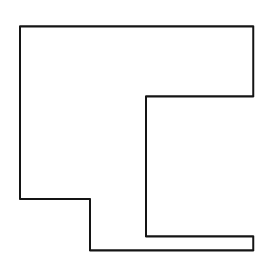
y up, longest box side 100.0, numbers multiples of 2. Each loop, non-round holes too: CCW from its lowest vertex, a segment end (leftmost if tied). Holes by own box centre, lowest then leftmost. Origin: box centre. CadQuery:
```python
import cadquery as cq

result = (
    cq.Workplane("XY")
    .moveTo(-20.0, -48.0)
    .lineTo(50.0, -48.0)
    .lineTo(50.0, -42.0)
    .lineTo(4.0, -42.0)
    .lineTo(4.0, 18.0)
    .lineTo(50.0, 18.0)
    .lineTo(50.0, 48.0)
    .lineTo(-50.0, 48.0)
    .lineTo(-50.0, -26.0)
    .lineTo(-20.0, -26.0)
    .close()
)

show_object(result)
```